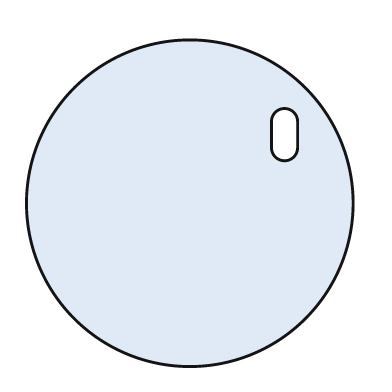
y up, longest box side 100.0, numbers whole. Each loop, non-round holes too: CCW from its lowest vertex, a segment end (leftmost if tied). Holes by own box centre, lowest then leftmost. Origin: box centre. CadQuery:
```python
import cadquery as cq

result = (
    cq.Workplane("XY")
    .moveTo(0.0, 0.0)
    .circle(50.0)
    .moveTo(25.0, 17.0)
    .threePointArc((29.0, 13.0), (33.0, 17.0))
    .lineTo(33.0, 25.0)
    .threePointArc((29.0, 29.0), (25.0, 25.0))
    .close()
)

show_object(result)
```